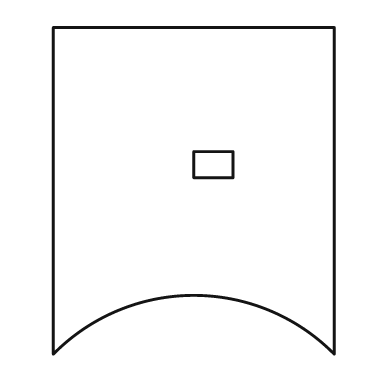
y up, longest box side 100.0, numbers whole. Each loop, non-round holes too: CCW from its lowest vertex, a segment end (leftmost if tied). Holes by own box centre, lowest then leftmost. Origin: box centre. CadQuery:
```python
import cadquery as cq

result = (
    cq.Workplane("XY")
    .moveTo(-43.0, -50.0)
    .threePointArc((0.0, -32.0), (43.0, -50.0))
    .lineTo(43.0, 50.0)
    .lineTo(-43.0, 50.0)
    .close()
    .moveTo(0.0, 4.0)
    .lineTo(12.0, 4.0)
    .lineTo(12.0, 12.0)
    .lineTo(0.0, 12.0)
    .close()
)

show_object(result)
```